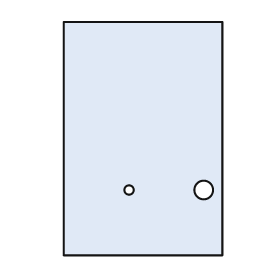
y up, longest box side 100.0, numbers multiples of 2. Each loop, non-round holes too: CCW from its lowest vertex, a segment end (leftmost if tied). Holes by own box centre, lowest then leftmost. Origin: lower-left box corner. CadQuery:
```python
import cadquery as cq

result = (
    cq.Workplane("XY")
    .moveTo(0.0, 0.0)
    .lineTo(68.0, 0.0)
    .lineTo(68.0, 100.0)
    .lineTo(0.0, 100.0)
    .close()
    .moveTo(28.0, 28.0)
    .circle(2.0)
    .moveTo(60.0, 28.0)
    .circle(4.0)
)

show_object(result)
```